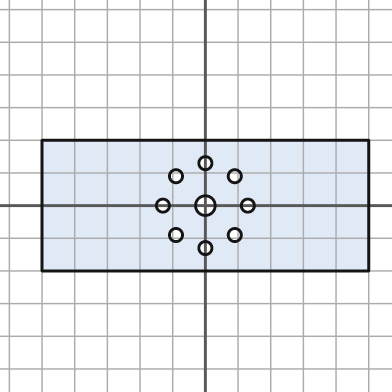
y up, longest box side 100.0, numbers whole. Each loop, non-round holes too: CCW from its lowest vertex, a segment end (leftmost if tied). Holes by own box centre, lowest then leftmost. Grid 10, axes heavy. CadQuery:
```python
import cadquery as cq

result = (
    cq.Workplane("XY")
    .moveTo(-50.0, -20.0)
    .lineTo(50.0, -20.0)
    .lineTo(50.0, 20.0)
    .lineTo(-50.0, 20.0)
    .close()
    .moveTo(0.0, -13.0)
    .circle(2.0)
    .moveTo(-9.0, -9.0)
    .circle(2.0)
    .moveTo(9.0, -9.0)
    .circle(2.0)
    .moveTo(-13.0, 0.0)
    .circle(2.0)
    .moveTo(0.0, 0.0)
    .circle(3.0)
    .moveTo(13.0, 0.0)
    .circle(2.0)
    .moveTo(-9.0, 9.0)
    .circle(2.0)
    .moveTo(9.0, 9.0)
    .circle(2.0)
    .moveTo(0.0, 13.0)
    .circle(2.0)
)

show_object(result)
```